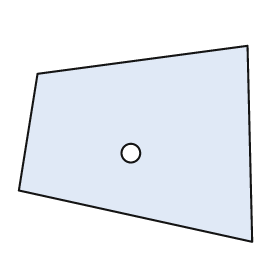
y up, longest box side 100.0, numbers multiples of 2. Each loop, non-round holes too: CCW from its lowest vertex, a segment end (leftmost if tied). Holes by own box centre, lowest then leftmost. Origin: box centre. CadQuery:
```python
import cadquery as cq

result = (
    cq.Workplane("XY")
    .moveTo(50.0, -42.0)
    .lineTo(48.0, 42.0)
    .lineTo(-42.0, 30.0)
    .lineTo(-50.0, -20.0)
    .close()
    .moveTo(-2.0, -4.0)
    .circle(4.0)
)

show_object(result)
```